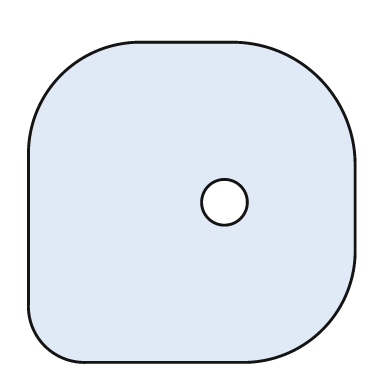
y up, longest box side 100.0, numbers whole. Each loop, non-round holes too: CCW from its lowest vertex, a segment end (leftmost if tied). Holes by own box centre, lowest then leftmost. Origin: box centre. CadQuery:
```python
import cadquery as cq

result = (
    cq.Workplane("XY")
    .moveTo(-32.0, -49.0)
    .lineTo(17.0, -49.0)
    .threePointArc((40.0, -39.0), (50.0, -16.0))
    .lineTo(50.0, 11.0)
    .threePointArc((39.0, 38.0), (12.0, 49.0))
    .lineTo(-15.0, 49.0)
    .threePointArc((-40.0, 39.0), (-50.0, 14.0))
    .lineTo(-50.0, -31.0)
    .threePointArc((-45.0, -44.0), (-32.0, -49.0))
    .close()
    .moveTo(10.0, 0.0)
    .circle(7.0)
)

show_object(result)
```